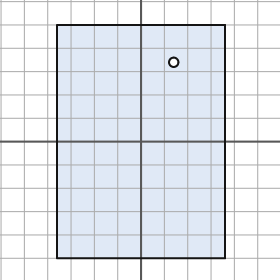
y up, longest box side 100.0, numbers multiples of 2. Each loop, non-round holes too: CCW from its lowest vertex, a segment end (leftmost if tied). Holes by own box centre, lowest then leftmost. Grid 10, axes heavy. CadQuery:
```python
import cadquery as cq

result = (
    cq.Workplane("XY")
    .moveTo(-36.0, -50.0)
    .lineTo(36.0, -50.0)
    .lineTo(36.0, 50.0)
    .lineTo(-36.0, 50.0)
    .close()
    .moveTo(14.0, 34.0)
    .circle(2.0)
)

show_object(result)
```